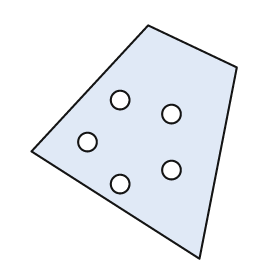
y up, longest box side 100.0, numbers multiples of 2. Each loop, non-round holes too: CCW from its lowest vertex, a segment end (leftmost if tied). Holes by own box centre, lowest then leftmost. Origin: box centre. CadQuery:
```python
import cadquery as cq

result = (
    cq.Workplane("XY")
    .moveTo(28.0, -50.0)
    .lineTo(44.0, 32.0)
    .lineTo(6.0, 50.0)
    .lineTo(-44.0, -4.0)
    .close()
    .moveTo(-6.0, -18.0)
    .circle(4.0)
    .moveTo(16.0, -12.0)
    .circle(4.0)
    .moveTo(-20.0, 0.0)
    .circle(4.0)
    .moveTo(16.0, 12.0)
    .circle(4.0)
    .moveTo(-6.0, 18.0)
    .circle(4.0)
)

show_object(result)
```